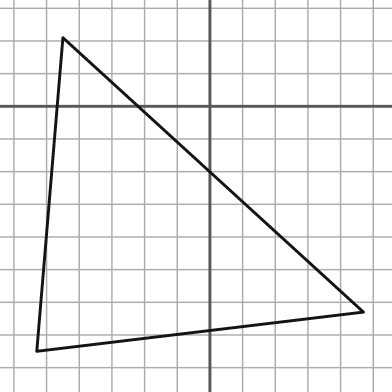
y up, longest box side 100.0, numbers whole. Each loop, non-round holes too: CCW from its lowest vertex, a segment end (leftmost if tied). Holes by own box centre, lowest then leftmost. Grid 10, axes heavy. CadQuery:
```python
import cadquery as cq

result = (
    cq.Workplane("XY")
    .moveTo(-53.0, -75.0)
    .lineTo(47.0, -63.0)
    .lineTo(-45.0, 21.0)
    .close()
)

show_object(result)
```